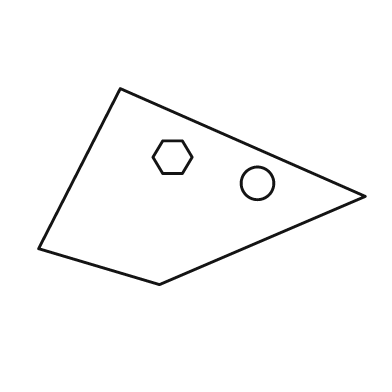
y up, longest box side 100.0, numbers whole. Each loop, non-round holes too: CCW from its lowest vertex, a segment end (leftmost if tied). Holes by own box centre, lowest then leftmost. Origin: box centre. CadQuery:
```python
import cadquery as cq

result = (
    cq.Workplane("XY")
    .moveTo(-13.0, -30.0)
    .lineTo(50.0, -3.0)
    .lineTo(-25.0, 30.0)
    .lineTo(-50.0, -19.0)
    .close()
    .moveTo(17.0, 1.0)
    .circle(5.0)
    .moveTo(-12.0, 4.0)
    .lineTo(-6.0, 4.0)
    .lineTo(-3.0, 9.0)
    .lineTo(-6.0, 14.0)
    .lineTo(-12.0, 14.0)
    .lineTo(-15.0, 9.0)
    .close()
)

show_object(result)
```